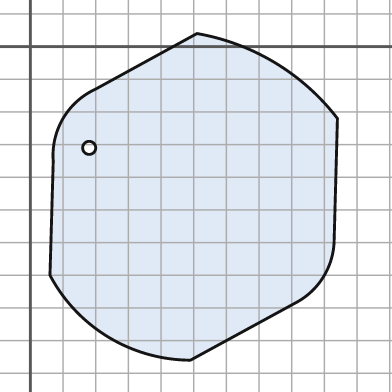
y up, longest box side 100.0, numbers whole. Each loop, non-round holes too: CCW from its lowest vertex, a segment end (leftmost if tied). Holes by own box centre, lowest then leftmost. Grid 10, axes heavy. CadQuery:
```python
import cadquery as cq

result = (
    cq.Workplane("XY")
    .moveTo(49.0, -96.0)
    .lineTo(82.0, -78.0)
    .threePointArc((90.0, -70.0), (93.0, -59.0))
    .lineTo(94.0, -22.0)
    .threePointArc((75.0, -5.0), (51.0, 4.0))
    .lineTo(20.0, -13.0)
    .threePointArc((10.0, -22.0), (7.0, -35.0))
    .lineTo(6.0, -70.0)
    .threePointArc((24.0, -89.0), (49.0, -96.0))
    .close()
    .moveTo(18.0, -31.0)
    .circle(2.0)
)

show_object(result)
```